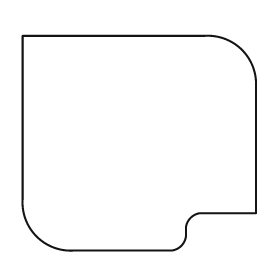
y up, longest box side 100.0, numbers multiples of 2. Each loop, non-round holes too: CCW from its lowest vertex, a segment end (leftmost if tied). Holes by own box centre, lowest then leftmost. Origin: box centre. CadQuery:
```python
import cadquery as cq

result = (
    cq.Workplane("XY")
    .moveTo(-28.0, -46.0)
    .lineTo(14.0, -46.0)
    .threePointArc((18.0, -44.0), (20.0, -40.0))
    .lineTo(20.0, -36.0)
    .threePointArc((22.0, -32.0), (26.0, -30.0))
    .lineTo(50.0, -30.0)
    .lineTo(50.0, 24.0)
    .threePointArc((44.0, 40.0), (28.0, 46.0))
    .lineTo(-50.0, 46.0)
    .lineTo(-50.0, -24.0)
    .threePointArc((-44.0, -40.0), (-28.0, -46.0))
    .close()
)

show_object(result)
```